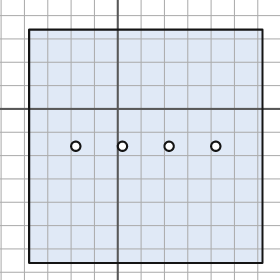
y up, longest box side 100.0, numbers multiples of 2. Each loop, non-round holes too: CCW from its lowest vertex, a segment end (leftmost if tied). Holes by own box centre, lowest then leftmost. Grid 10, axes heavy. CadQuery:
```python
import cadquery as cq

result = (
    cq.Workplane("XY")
    .moveTo(-38.0, -66.0)
    .lineTo(62.0, -66.0)
    .lineTo(62.0, 34.0)
    .lineTo(-38.0, 34.0)
    .close()
    .moveTo(-18.0, -16.0)
    .circle(2.0)
    .moveTo(2.0, -16.0)
    .circle(2.0)
    .moveTo(22.0, -16.0)
    .circle(2.0)
    .moveTo(42.0, -16.0)
    .circle(2.0)
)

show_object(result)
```